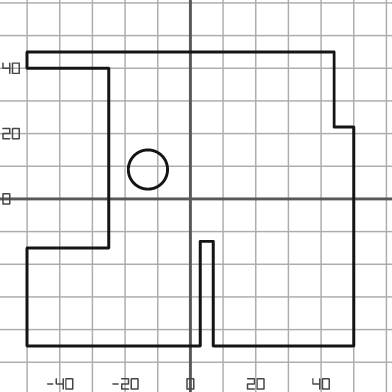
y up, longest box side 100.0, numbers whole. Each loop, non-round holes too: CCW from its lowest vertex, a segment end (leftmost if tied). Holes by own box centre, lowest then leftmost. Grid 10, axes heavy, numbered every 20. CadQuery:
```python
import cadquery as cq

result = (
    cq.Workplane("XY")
    .moveTo(-50.0, -45.0)
    .lineTo(3.0, -45.0)
    .lineTo(3.0, -13.0)
    .lineTo(7.0, -13.0)
    .lineTo(7.0, -45.0)
    .lineTo(50.0, -45.0)
    .lineTo(50.0, 22.0)
    .lineTo(44.0, 22.0)
    .lineTo(44.0, 45.0)
    .lineTo(-50.0, 45.0)
    .lineTo(-50.0, 40.0)
    .lineTo(-25.0, 40.0)
    .lineTo(-25.0, -15.0)
    .lineTo(-50.0, -15.0)
    .close()
    .moveTo(-13.0, 9.0)
    .circle(6.0)
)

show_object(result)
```